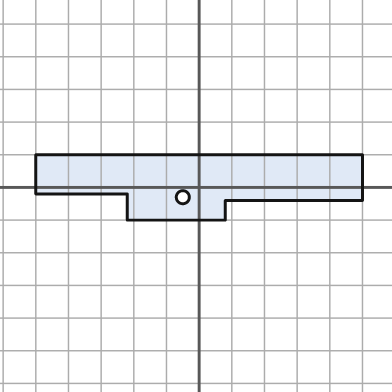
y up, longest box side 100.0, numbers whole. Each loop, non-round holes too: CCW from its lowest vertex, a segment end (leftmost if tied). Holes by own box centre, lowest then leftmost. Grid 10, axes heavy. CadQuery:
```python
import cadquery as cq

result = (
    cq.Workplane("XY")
    .moveTo(-22.0, -10.0)
    .lineTo(8.0, -10.0)
    .lineTo(8.0, -4.0)
    .lineTo(50.0, -4.0)
    .lineTo(50.0, 10.0)
    .lineTo(-50.0, 10.0)
    .lineTo(-50.0, -2.0)
    .lineTo(-22.0, -2.0)
    .close()
    .moveTo(-5.0, -3.0)
    .circle(2.0)
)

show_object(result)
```